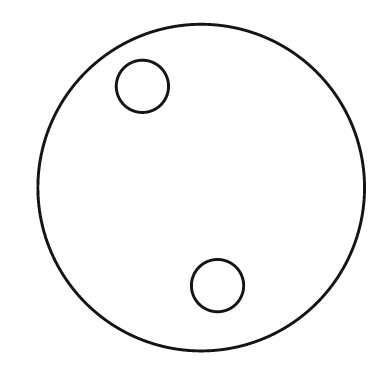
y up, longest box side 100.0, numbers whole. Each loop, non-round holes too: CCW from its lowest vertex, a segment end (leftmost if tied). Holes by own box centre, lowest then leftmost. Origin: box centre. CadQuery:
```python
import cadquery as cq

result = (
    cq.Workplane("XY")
    .moveTo(0.0, 0.0)
    .circle(50.0)
    .moveTo(5.0, -30.0)
    .circle(8.0)
    .moveTo(-18.0, 31.0)
    .circle(8.0)
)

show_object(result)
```